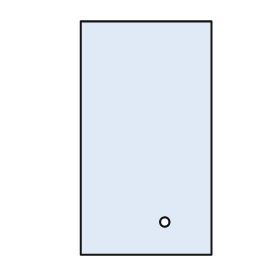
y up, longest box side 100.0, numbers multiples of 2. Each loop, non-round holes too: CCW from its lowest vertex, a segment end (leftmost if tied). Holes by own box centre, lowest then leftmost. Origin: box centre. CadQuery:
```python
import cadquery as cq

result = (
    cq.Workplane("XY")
    .moveTo(-28.0, -50.0)
    .lineTo(28.0, -50.0)
    .lineTo(28.0, 50.0)
    .lineTo(-28.0, 50.0)
    .close()
    .moveTo(8.0, -36.0)
    .circle(2.0)
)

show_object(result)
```